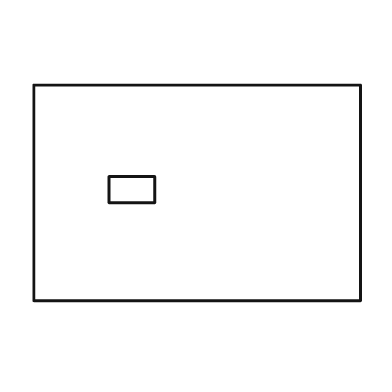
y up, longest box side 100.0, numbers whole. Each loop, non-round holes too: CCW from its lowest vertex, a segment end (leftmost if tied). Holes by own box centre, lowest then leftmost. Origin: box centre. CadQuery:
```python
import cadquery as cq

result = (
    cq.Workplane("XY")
    .moveTo(-50.0, -33.0)
    .lineTo(50.0, -33.0)
    .lineTo(50.0, 33.0)
    .lineTo(-50.0, 33.0)
    .close()
    .moveTo(-27.0, -3.0)
    .lineTo(-13.0, -3.0)
    .lineTo(-13.0, 5.0)
    .lineTo(-27.0, 5.0)
    .close()
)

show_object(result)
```